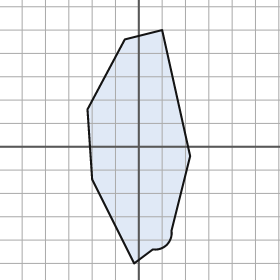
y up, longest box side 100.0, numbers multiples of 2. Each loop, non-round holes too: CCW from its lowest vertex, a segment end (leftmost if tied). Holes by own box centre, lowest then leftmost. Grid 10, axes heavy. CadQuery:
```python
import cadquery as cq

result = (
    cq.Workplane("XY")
    .moveTo(-2.0, -50.0)
    .lineTo(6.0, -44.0)
    .threePointArc((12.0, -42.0), (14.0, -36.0))
    .lineTo(22.0, -4.0)
    .lineTo(10.0, 50.0)
    .lineTo(-6.0, 46.0)
    .lineTo(-22.0, 16.0)
    .lineTo(-20.0, -14.0)
    .close()
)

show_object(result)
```